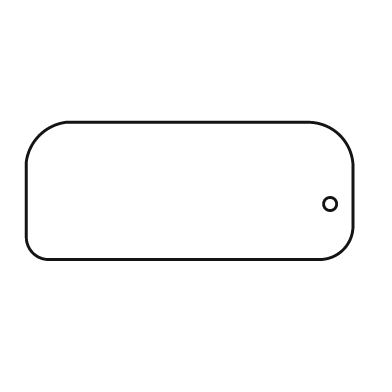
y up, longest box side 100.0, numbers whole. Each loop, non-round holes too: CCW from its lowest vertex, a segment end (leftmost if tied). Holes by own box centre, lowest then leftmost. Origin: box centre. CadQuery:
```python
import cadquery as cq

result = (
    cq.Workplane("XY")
    .moveTo(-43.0, -21.0)
    .lineTo(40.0, -21.0)
    .threePointArc((47.0, -18.0), (50.0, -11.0))
    .lineTo(50.0, 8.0)
    .threePointArc((46.0, 17.0), (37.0, 21.0))
    .lineTo(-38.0, 21.0)
    .threePointArc((-46.0, 17.0), (-50.0, 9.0))
    .lineTo(-50.0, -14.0)
    .threePointArc((-48.0, -19.0), (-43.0, -21.0))
    .close()
    .moveTo(43.0, -4.0)
    .circle(2.0)
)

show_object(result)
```